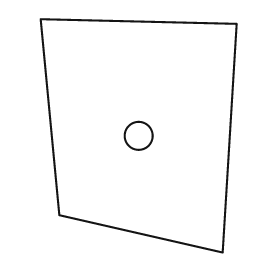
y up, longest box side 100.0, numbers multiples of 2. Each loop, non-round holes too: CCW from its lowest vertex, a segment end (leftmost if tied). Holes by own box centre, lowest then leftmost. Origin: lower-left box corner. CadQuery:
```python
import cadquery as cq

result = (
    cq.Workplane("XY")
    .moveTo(78.0, 0.0)
    .lineTo(84.0, 98.0)
    .lineTo(0.0, 100.0)
    .lineTo(8.0, 16.0)
    .close()
    .moveTo(42.0, 50.0)
    .circle(6.0)
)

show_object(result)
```